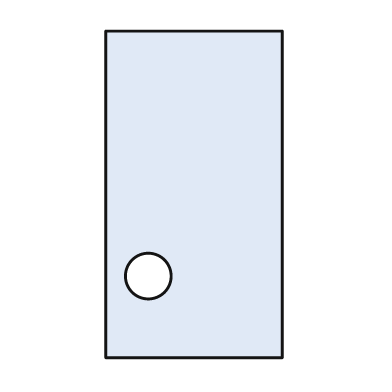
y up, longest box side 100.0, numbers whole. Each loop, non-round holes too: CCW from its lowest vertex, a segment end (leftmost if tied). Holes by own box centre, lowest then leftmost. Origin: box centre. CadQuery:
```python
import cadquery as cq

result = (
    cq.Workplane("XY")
    .moveTo(-27.0, -50.0)
    .lineTo(27.0, -50.0)
    .lineTo(27.0, 50.0)
    .lineTo(-27.0, 50.0)
    .close()
    .moveTo(-14.0, -25.0)
    .circle(7.0)
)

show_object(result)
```